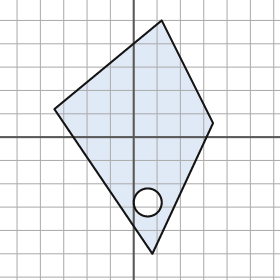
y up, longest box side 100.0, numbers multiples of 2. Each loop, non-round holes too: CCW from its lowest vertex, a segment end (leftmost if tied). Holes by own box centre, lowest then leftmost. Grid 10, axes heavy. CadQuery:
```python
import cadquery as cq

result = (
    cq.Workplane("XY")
    .moveTo(8.0, -50.0)
    .lineTo(34.0, 6.0)
    .lineTo(12.0, 50.0)
    .lineTo(-34.0, 12.0)
    .close()
    .moveTo(6.0, -28.0)
    .circle(6.0)
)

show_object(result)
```